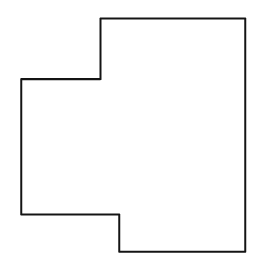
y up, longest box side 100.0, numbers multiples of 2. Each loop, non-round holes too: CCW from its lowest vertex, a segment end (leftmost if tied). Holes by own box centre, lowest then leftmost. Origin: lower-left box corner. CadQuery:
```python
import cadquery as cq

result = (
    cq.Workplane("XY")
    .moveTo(42.0, 0.0)
    .lineTo(96.0, 0.0)
    .lineTo(96.0, 100.0)
    .lineTo(34.0, 100.0)
    .lineTo(34.0, 74.0)
    .lineTo(0.0, 74.0)
    .lineTo(0.0, 16.0)
    .lineTo(42.0, 16.0)
    .close()
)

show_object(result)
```